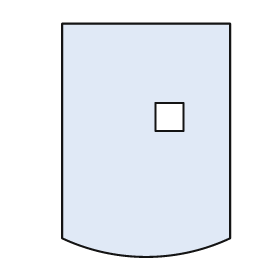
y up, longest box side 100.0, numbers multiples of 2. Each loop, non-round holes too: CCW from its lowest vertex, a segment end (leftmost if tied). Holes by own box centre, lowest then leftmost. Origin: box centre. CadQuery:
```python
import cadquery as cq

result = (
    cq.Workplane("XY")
    .moveTo(-36.0, -42.0)
    .threePointArc((0.0, -50.0), (36.0, -42.0))
    .lineTo(36.0, 50.0)
    .lineTo(-36.0, 50.0)
    .close()
    .moveTo(4.0, 4.0)
    .lineTo(16.0, 4.0)
    .lineTo(16.0, 16.0)
    .lineTo(4.0, 16.0)
    .close()
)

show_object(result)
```